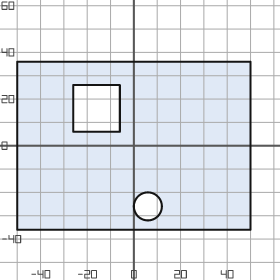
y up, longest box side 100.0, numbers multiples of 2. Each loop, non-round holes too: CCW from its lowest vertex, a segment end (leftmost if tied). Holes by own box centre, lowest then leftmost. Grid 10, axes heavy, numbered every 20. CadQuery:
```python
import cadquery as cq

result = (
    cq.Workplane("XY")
    .moveTo(-50.0, -36.0)
    .lineTo(50.0, -36.0)
    .lineTo(50.0, 36.0)
    .lineTo(-50.0, 36.0)
    .close()
    .moveTo(6.0, -26.0)
    .circle(6.0)
    .moveTo(-26.0, 6.0)
    .lineTo(-6.0, 6.0)
    .lineTo(-6.0, 26.0)
    .lineTo(-26.0, 26.0)
    .close()
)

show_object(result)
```